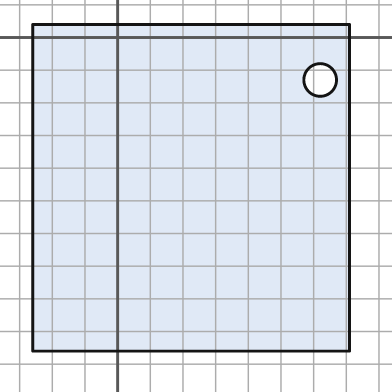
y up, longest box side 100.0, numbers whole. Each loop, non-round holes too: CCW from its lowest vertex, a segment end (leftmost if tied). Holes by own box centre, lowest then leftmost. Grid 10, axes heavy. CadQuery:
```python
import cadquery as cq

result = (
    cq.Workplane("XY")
    .moveTo(-26.0, -96.0)
    .lineTo(71.0, -96.0)
    .lineTo(71.0, 4.0)
    .lineTo(-26.0, 4.0)
    .close()
    .moveTo(62.0, -13.0)
    .circle(5.0)
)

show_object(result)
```